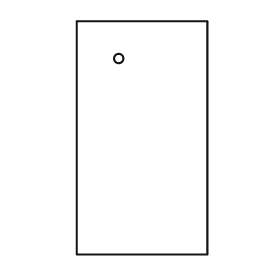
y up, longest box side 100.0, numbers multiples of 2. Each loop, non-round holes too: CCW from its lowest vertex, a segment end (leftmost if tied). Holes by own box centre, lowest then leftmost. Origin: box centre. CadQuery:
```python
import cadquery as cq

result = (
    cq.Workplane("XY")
    .moveTo(-28.0, -50.0)
    .lineTo(28.0, -50.0)
    .lineTo(28.0, 50.0)
    .lineTo(-28.0, 50.0)
    .close()
    .moveTo(-10.0, 34.0)
    .circle(2.0)
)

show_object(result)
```